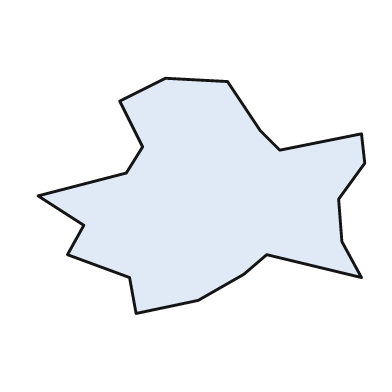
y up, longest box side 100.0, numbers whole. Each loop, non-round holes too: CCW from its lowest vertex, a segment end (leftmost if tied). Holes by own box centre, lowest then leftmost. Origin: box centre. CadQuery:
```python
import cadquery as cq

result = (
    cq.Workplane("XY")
    .moveTo(-20.0, -36.0)
    .lineTo(-1.0, -32.0)
    .lineTo(13.0, -24.0)
    .lineTo(20.0, -18.0)
    .lineTo(49.0, -25.0)
    .lineTo(43.0, -14.0)
    .lineTo(42.0, -1.0)
    .lineTo(50.0, 10.0)
    .lineTo(49.0, 19.0)
    .lineTo(24.0, 14.0)
    .lineTo(18.0, 20.0)
    .lineTo(8.0, 35.0)
    .lineTo(-11.0, 36.0)
    .lineTo(-25.0, 29.0)
    .lineTo(-18.0, 15.0)
    .lineTo(-23.0, 7.0)
    .lineTo(-50.0, 0.0)
    .lineTo(-36.0, -9.0)
    .lineTo(-41.0, -18.0)
    .lineTo(-22.0, -25.0)
    .close()
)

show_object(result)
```